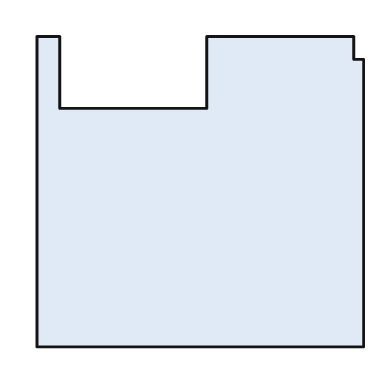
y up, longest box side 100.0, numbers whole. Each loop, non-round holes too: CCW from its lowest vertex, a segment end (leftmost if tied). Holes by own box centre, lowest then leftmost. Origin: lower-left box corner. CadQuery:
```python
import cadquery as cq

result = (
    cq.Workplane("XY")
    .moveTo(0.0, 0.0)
    .lineTo(100.0, 0.0)
    .lineTo(100.0, 88.0)
    .lineTo(97.0, 88.0)
    .lineTo(97.0, 95.0)
    .lineTo(52.0, 95.0)
    .lineTo(52.0, 73.0)
    .lineTo(7.0, 73.0)
    .lineTo(7.0, 95.0)
    .lineTo(0.0, 95.0)
    .close()
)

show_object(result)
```